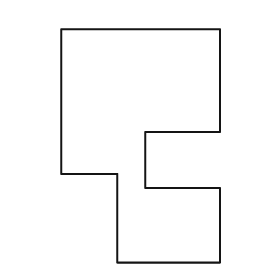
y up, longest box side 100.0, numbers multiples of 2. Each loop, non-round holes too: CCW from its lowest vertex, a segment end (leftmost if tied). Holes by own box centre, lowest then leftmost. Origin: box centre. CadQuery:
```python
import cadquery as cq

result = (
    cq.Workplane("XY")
    .moveTo(-10.0, -50.0)
    .lineTo(34.0, -50.0)
    .lineTo(34.0, -18.0)
    .lineTo(2.0, -18.0)
    .lineTo(2.0, 6.0)
    .lineTo(34.0, 6.0)
    .lineTo(34.0, 50.0)
    .lineTo(-34.0, 50.0)
    .lineTo(-34.0, -12.0)
    .lineTo(-10.0, -12.0)
    .close()
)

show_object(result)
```